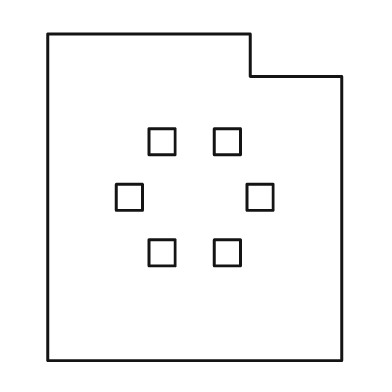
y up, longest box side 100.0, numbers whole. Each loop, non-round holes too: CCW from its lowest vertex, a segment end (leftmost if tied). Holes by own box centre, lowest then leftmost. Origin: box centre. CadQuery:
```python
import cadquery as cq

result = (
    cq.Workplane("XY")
    .moveTo(-45.0, -50.0)
    .lineTo(45.0, -50.0)
    .lineTo(45.0, 37.0)
    .lineTo(17.0, 37.0)
    .lineTo(17.0, 50.0)
    .lineTo(-45.0, 50.0)
    .close()
    .moveTo(-14.0, -21.0)
    .lineTo(-6.0, -21.0)
    .lineTo(-6.0, -13.0)
    .lineTo(-14.0, -13.0)
    .close()
    .moveTo(6.0, -21.0)
    .lineTo(14.0, -21.0)
    .lineTo(14.0, -13.0)
    .lineTo(6.0, -13.0)
    .close()
    .moveTo(-24.0, -4.0)
    .lineTo(-16.0, -4.0)
    .lineTo(-16.0, 4.0)
    .lineTo(-24.0, 4.0)
    .close()
    .moveTo(16.0, -4.0)
    .lineTo(24.0, -4.0)
    .lineTo(24.0, 4.0)
    .lineTo(16.0, 4.0)
    .close()
    .moveTo(-14.0, 13.0)
    .lineTo(-6.0, 13.0)
    .lineTo(-6.0, 21.0)
    .lineTo(-14.0, 21.0)
    .close()
    .moveTo(6.0, 13.0)
    .lineTo(14.0, 13.0)
    .lineTo(14.0, 21.0)
    .lineTo(6.0, 21.0)
    .close()
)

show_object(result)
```